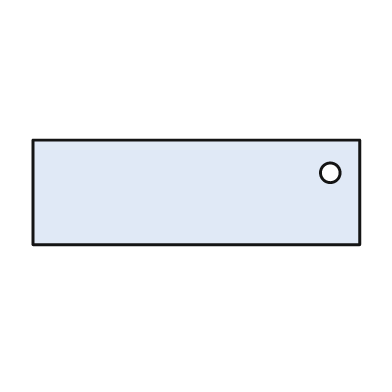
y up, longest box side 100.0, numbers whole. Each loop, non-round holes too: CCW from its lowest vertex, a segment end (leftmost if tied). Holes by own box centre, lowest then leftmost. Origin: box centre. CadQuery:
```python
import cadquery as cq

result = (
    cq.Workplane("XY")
    .moveTo(-50.0, -16.0)
    .lineTo(50.0, -16.0)
    .lineTo(50.0, 16.0)
    .lineTo(-50.0, 16.0)
    .close()
    .moveTo(41.0, 6.0)
    .circle(3.0)
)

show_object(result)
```